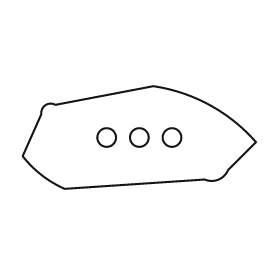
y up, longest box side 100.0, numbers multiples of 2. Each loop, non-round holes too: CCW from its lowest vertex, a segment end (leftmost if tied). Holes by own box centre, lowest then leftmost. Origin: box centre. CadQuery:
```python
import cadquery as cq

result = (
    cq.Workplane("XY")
    .moveTo(-32.0, -22.0)
    .lineTo(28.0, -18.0)
    .threePointArc((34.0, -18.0), (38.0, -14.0))
    .lineTo(50.0, -2.0)
    .threePointArc((30.0, 14.0), (6.0, 22.0))
    .lineTo(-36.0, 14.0)
    .threePointArc((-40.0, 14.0), (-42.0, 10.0))
    .lineTo(-50.0, -8.0)
    .threePointArc((-42.0, -16.0), (-32.0, -22.0))
    .close()
    .moveTo(-14.0, 0.0)
    .circle(4.0)
    .moveTo(0.0, 0.0)
    .circle(4.0)
    .moveTo(14.0, 0.0)
    .circle(4.0)
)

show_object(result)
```